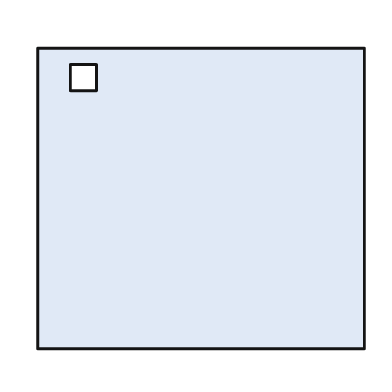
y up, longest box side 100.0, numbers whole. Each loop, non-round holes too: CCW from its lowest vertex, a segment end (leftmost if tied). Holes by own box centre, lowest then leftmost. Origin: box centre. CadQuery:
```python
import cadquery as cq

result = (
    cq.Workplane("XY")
    .moveTo(-50.0, -46.0)
    .lineTo(50.0, -46.0)
    .lineTo(50.0, 46.0)
    .lineTo(-50.0, 46.0)
    .close()
    .moveTo(-40.0, 33.0)
    .lineTo(-32.0, 33.0)
    .lineTo(-32.0, 41.0)
    .lineTo(-40.0, 41.0)
    .close()
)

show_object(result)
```